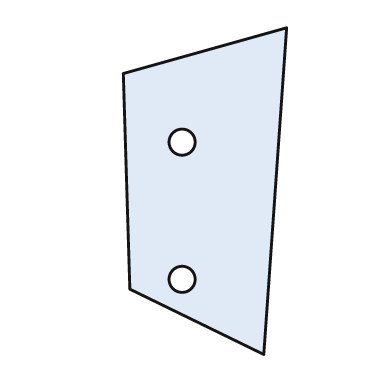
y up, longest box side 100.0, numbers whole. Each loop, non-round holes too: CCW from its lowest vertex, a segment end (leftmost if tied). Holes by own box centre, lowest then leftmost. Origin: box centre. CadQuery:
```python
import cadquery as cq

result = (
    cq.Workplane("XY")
    .moveTo(18.0, -50.0)
    .lineTo(25.0, 50.0)
    .lineTo(-25.0, 36.0)
    .lineTo(-23.0, -30.0)
    .close()
    .moveTo(-7.0, -27.0)
    .circle(4.0)
    .moveTo(-7.0, 15.0)
    .circle(4.0)
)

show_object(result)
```